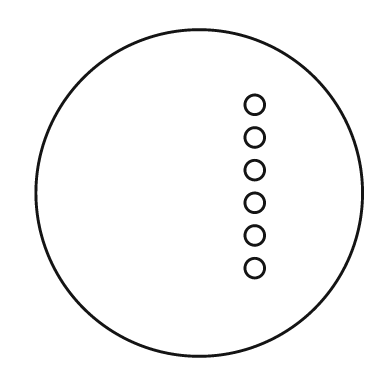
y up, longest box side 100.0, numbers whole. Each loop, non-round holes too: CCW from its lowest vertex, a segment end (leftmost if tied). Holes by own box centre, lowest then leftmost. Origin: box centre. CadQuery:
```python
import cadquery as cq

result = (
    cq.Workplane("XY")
    .moveTo(0.0, 0.0)
    .circle(50.0)
    .moveTo(17.0, -23.0)
    .circle(3.0)
    .moveTo(17.0, -13.0)
    .circle(3.0)
    .moveTo(17.0, -3.0)
    .circle(3.0)
    .moveTo(17.0, 7.0)
    .circle(3.0)
    .moveTo(17.0, 17.0)
    .circle(3.0)
    .moveTo(17.0, 27.0)
    .circle(3.0)
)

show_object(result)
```